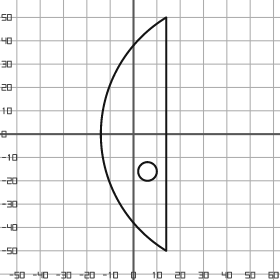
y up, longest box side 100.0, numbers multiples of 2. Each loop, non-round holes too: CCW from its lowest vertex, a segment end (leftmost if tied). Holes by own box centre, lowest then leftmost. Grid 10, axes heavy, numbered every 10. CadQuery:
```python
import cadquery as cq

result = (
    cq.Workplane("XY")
    .moveTo(14.0, -50.0)
    .lineTo(14.0, 50.0)
    .threePointArc((-14.0, 0.0), (14.0, -50.0))
    .close()
    .moveTo(6.0, -16.0)
    .circle(4.0)
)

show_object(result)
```